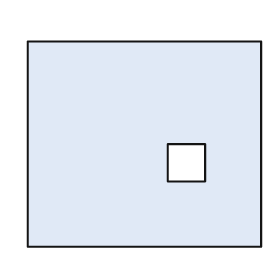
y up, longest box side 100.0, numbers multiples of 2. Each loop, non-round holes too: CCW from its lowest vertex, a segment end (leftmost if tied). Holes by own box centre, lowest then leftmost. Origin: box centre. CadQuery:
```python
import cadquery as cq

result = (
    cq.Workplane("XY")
    .moveTo(-50.0, -44.0)
    .lineTo(50.0, -44.0)
    .lineTo(50.0, 44.0)
    .lineTo(-50.0, 44.0)
    .close()
    .moveTo(10.0, -16.0)
    .lineTo(26.0, -16.0)
    .lineTo(26.0, 0.0)
    .lineTo(10.0, 0.0)
    .close()
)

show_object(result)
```